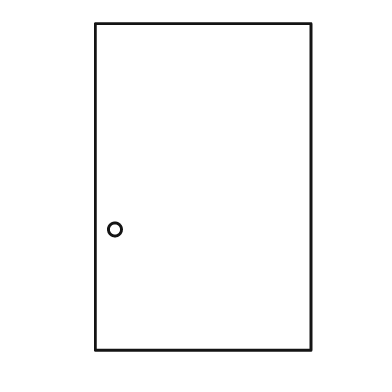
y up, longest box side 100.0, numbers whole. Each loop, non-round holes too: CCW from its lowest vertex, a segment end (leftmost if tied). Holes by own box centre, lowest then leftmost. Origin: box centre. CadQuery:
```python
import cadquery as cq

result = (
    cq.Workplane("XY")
    .moveTo(-33.0, -50.0)
    .lineTo(33.0, -50.0)
    .lineTo(33.0, 50.0)
    .lineTo(-33.0, 50.0)
    .close()
    .moveTo(-27.0, -13.0)
    .circle(2.0)
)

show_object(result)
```